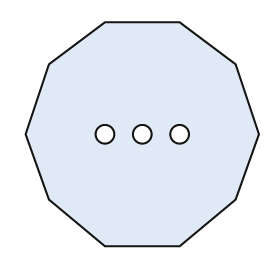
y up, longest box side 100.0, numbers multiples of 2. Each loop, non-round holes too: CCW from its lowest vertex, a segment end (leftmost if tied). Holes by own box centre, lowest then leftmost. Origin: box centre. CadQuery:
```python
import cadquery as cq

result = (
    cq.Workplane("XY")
    .moveTo(-16.0, -48.0)
    .lineTo(16.0, -48.0)
    .lineTo(40.0, -28.0)
    .lineTo(50.0, 0.0)
    .lineTo(40.0, 30.0)
    .lineTo(16.0, 48.0)
    .lineTo(-16.0, 48.0)
    .lineTo(-40.0, 30.0)
    .lineTo(-50.0, 0.0)
    .lineTo(-40.0, -28.0)
    .close()
    .moveTo(-16.0, 0.0)
    .circle(4.0)
    .moveTo(0.0, 0.0)
    .circle(4.0)
    .moveTo(16.0, 0.0)
    .circle(4.0)
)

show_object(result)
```